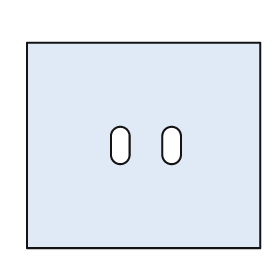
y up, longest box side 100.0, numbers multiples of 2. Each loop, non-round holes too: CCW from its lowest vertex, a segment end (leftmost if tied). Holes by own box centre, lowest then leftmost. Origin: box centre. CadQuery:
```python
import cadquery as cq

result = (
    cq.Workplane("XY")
    .moveTo(-50.0, -44.0)
    .lineTo(50.0, -44.0)
    .lineTo(50.0, 44.0)
    .lineTo(-50.0, 44.0)
    .close()
    .moveTo(-14.0, -4.0)
    .threePointArc((-10.0, -8.0), (-6.0, -4.0))
    .lineTo(-6.0, 4.0)
    .threePointArc((-10.0, 8.0), (-14.0, 4.0))
    .close()
    .moveTo(8.0, -4.0)
    .threePointArc((12.0, -8.0), (16.0, -4.0))
    .lineTo(16.0, 4.0)
    .threePointArc((12.0, 8.0), (8.0, 4.0))
    .close()
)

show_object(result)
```